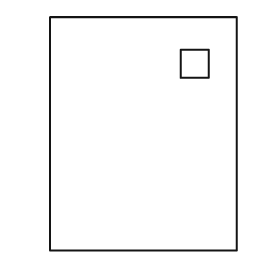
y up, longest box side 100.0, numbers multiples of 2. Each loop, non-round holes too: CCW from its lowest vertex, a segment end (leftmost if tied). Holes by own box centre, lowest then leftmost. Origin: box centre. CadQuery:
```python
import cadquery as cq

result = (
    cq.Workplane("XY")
    .moveTo(-40.0, -50.0)
    .lineTo(40.0, -50.0)
    .lineTo(40.0, 50.0)
    .lineTo(-40.0, 50.0)
    .close()
    .moveTo(16.0, 24.0)
    .lineTo(28.0, 24.0)
    .lineTo(28.0, 36.0)
    .lineTo(16.0, 36.0)
    .close()
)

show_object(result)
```